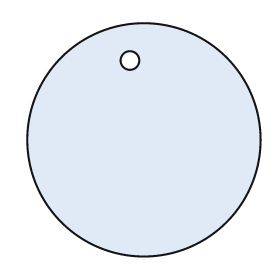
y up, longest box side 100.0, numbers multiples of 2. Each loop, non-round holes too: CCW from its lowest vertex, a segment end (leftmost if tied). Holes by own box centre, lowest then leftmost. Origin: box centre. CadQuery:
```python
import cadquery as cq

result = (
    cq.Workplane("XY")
    .moveTo(0.0, 0.0)
    .circle(50.0)
    .moveTo(-6.0, 34.0)
    .circle(4.0)
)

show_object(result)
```